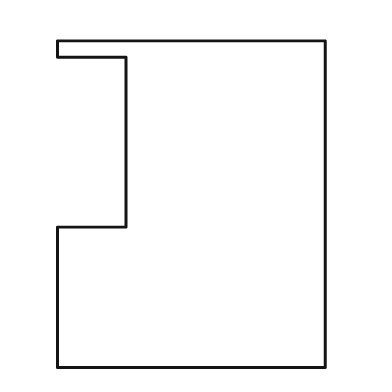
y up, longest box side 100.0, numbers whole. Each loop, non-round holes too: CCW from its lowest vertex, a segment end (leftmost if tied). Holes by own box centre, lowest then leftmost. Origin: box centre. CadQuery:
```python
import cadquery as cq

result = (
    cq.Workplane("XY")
    .moveTo(-41.0, -50.0)
    .lineTo(41.0, -50.0)
    .lineTo(41.0, 50.0)
    .lineTo(-41.0, 50.0)
    .lineTo(-41.0, 45.0)
    .lineTo(-20.0, 45.0)
    .lineTo(-20.0, -7.0)
    .lineTo(-41.0, -7.0)
    .close()
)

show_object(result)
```